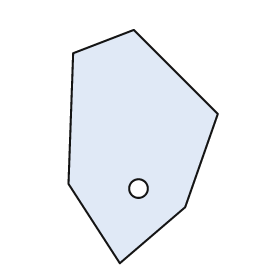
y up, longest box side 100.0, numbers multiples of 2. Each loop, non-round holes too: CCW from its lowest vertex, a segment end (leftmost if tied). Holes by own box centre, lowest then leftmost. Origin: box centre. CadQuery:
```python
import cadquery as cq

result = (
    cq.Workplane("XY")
    .moveTo(-10.0, -50.0)
    .lineTo(18.0, -26.0)
    .lineTo(32.0, 14.0)
    .lineTo(-4.0, 50.0)
    .lineTo(-30.0, 40.0)
    .lineTo(-32.0, -16.0)
    .close()
    .moveTo(-2.0, -18.0)
    .circle(4.0)
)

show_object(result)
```